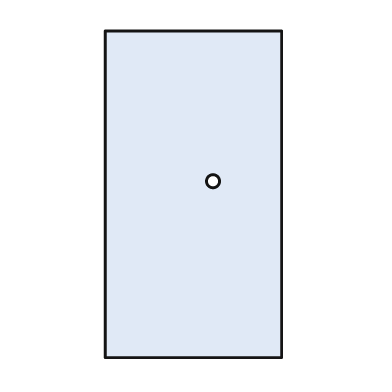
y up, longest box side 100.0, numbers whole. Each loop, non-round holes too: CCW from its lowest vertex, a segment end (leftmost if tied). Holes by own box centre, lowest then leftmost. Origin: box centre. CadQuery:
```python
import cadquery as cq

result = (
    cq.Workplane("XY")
    .moveTo(-27.0, -50.0)
    .lineTo(27.0, -50.0)
    .lineTo(27.0, 50.0)
    .lineTo(-27.0, 50.0)
    .close()
    .moveTo(6.0, 4.0)
    .circle(2.0)
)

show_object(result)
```